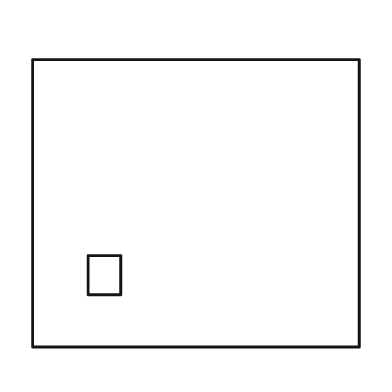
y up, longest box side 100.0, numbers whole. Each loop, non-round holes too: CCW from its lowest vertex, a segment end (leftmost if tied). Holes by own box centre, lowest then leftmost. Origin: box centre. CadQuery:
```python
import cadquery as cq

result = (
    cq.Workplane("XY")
    .moveTo(-50.0, -44.0)
    .lineTo(50.0, -44.0)
    .lineTo(50.0, 44.0)
    .lineTo(-50.0, 44.0)
    .close()
    .moveTo(-33.0, -28.0)
    .lineTo(-23.0, -28.0)
    .lineTo(-23.0, -16.0)
    .lineTo(-33.0, -16.0)
    .close()
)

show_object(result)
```